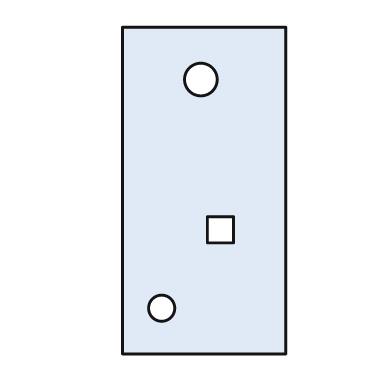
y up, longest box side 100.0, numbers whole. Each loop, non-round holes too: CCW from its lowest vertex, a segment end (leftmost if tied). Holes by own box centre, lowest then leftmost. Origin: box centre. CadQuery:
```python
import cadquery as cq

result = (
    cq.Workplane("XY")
    .moveTo(-25.0, -50.0)
    .lineTo(25.0, -50.0)
    .lineTo(25.0, 50.0)
    .lineTo(-25.0, 50.0)
    .close()
    .moveTo(-13.0, -36.0)
    .circle(4.0)
    .moveTo(1.0, -16.0)
    .lineTo(9.0, -16.0)
    .lineTo(9.0, -8.0)
    .lineTo(1.0, -8.0)
    .close()
    .moveTo(-1.0, 34.0)
    .circle(5.0)
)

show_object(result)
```